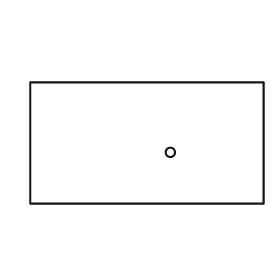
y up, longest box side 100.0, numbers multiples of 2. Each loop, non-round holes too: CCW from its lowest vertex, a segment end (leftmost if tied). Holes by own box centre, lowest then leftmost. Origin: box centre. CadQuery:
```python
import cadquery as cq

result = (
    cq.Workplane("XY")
    .moveTo(-50.0, -26.0)
    .lineTo(50.0, -26.0)
    .lineTo(50.0, 26.0)
    .lineTo(-50.0, 26.0)
    .close()
    .moveTo(10.0, -4.0)
    .circle(2.0)
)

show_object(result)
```